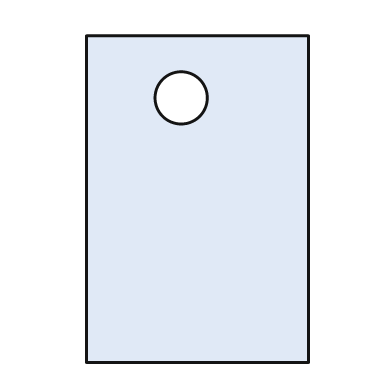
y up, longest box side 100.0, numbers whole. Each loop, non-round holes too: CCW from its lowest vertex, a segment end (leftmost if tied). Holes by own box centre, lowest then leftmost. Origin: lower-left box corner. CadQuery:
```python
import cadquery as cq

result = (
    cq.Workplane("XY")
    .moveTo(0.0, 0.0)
    .lineTo(68.0, 0.0)
    .lineTo(68.0, 100.0)
    .lineTo(0.0, 100.0)
    .close()
    .moveTo(29.0, 81.0)
    .circle(8.0)
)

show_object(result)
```